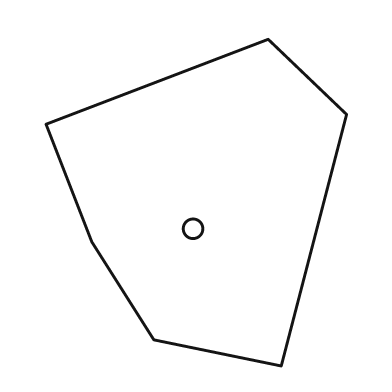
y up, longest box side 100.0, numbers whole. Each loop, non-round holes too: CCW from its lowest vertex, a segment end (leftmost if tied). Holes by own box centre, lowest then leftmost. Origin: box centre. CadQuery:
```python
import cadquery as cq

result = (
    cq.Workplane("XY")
    .moveTo(26.0, -50.0)
    .lineTo(46.0, 27.0)
    .lineTo(22.0, 50.0)
    .lineTo(-46.0, 24.0)
    .lineTo(-32.0, -12.0)
    .lineTo(-13.0, -42.0)
    .close()
    .moveTo(-1.0, -8.0)
    .circle(3.0)
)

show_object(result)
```